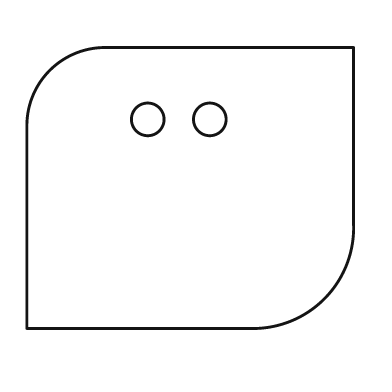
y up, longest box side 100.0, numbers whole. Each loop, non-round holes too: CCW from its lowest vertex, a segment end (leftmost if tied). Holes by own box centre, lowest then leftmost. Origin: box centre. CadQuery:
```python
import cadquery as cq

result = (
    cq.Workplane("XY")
    .moveTo(-50.0, -43.0)
    .lineTo(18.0, -43.0)
    .threePointArc((41.0, -34.0), (50.0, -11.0))
    .lineTo(50.0, 43.0)
    .lineTo(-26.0, 43.0)
    .threePointArc((-43.0, 36.0), (-50.0, 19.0))
    .close()
    .moveTo(-13.0, 21.0)
    .circle(5.0)
    .moveTo(6.0, 21.0)
    .circle(5.0)
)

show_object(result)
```